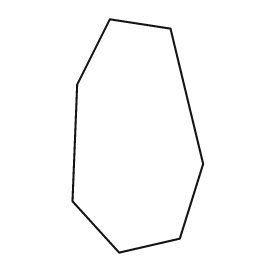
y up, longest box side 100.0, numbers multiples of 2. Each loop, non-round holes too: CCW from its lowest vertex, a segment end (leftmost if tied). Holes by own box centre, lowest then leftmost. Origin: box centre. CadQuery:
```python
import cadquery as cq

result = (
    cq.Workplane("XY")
    .moveTo(-8.0, -50.0)
    .lineTo(18.0, -44.0)
    .lineTo(28.0, -12.0)
    .lineTo(14.0, 46.0)
    .lineTo(-12.0, 50.0)
    .lineTo(-26.0, 22.0)
    .lineTo(-28.0, -28.0)
    .close()
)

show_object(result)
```